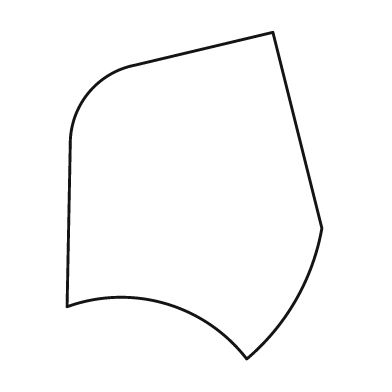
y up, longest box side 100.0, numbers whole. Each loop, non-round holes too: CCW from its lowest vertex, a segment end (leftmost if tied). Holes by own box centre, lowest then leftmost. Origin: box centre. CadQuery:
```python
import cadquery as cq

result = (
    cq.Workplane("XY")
    .moveTo(16.0, -50.0)
    .threePointArc((31.0, -32.0), (39.0, -10.0))
    .lineTo(24.0, 50.0)
    .lineTo(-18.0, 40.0)
    .threePointArc((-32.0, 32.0), (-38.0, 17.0))
    .lineTo(-39.0, -34.0)
    .threePointArc((-9.0, -33.0), (16.0, -50.0))
    .close()
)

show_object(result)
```